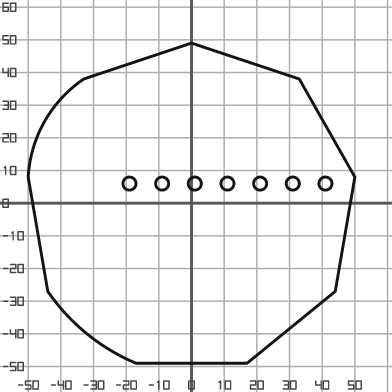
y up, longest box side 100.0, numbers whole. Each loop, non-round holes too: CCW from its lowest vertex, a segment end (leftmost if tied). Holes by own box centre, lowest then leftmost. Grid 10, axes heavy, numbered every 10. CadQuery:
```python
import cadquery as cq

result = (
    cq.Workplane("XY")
    .moveTo(-17.0, -49.0)
    .lineTo(17.0, -49.0)
    .lineTo(44.0, -27.0)
    .lineTo(50.0, 8.0)
    .lineTo(33.0, 38.0)
    .lineTo(0.0, 49.0)
    .lineTo(-33.0, 38.0)
    .threePointArc((-45.0, 25.0), (-50.0, 8.0))
    .lineTo(-44.0, -27.0)
    .threePointArc((-32.0, -40.0), (-17.0, -49.0))
    .close()
    .moveTo(-19.0, 6.0)
    .circle(2.0)
    .moveTo(-9.0, 6.0)
    .circle(2.0)
    .moveTo(1.0, 6.0)
    .circle(2.0)
    .moveTo(11.0, 6.0)
    .circle(2.0)
    .moveTo(21.0, 6.0)
    .circle(2.0)
    .moveTo(31.0, 6.0)
    .circle(2.0)
    .moveTo(41.0, 6.0)
    .circle(2.0)
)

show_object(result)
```